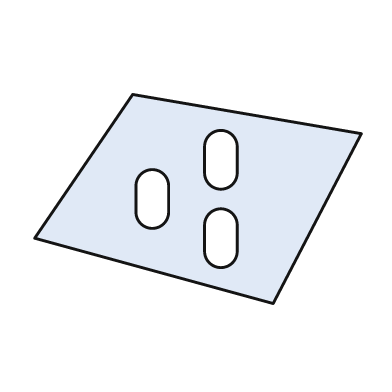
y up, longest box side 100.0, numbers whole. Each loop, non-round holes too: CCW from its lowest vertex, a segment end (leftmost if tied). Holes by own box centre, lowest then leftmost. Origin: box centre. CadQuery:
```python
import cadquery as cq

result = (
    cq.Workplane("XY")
    .moveTo(23.0, -32.0)
    .lineTo(50.0, 20.0)
    .lineTo(-20.0, 32.0)
    .lineTo(-50.0, -12.0)
    .close()
    .moveTo(2.0, -16.0)
    .threePointArc((7.0, -21.0), (12.0, -16.0))
    .lineTo(12.0, -8.0)
    .threePointArc((7.0, -3.0), (2.0, -8.0))
    .close()
    .moveTo(-19.0, -4.0)
    .threePointArc((-14.0, -9.0), (-9.0, -4.0))
    .lineTo(-9.0, 4.0)
    .threePointArc((-14.0, 9.0), (-19.0, 4.0))
    .close()
    .moveTo(2.0, 8.0)
    .threePointArc((7.0, 3.0), (12.0, 8.0))
    .lineTo(12.0, 16.0)
    .threePointArc((7.0, 21.0), (2.0, 16.0))
    .close()
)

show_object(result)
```